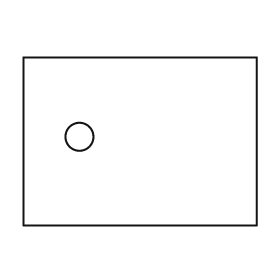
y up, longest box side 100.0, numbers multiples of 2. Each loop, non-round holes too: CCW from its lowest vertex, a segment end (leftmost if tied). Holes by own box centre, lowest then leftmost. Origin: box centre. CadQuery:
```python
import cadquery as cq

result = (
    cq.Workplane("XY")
    .moveTo(-50.0, -36.0)
    .lineTo(50.0, -36.0)
    .lineTo(50.0, 36.0)
    .lineTo(-50.0, 36.0)
    .close()
    .moveTo(-26.0, 2.0)
    .circle(6.0)
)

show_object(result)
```